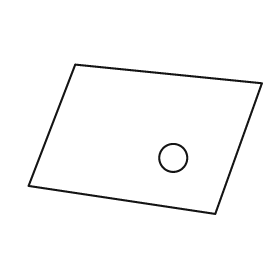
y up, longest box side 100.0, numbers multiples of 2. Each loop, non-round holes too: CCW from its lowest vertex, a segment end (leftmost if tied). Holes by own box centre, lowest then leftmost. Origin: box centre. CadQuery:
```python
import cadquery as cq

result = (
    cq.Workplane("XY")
    .moveTo(30.0, -32.0)
    .lineTo(50.0, 24.0)
    .lineTo(-30.0, 32.0)
    .lineTo(-50.0, -20.0)
    .close()
    .moveTo(12.0, -8.0)
    .circle(6.0)
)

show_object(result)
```